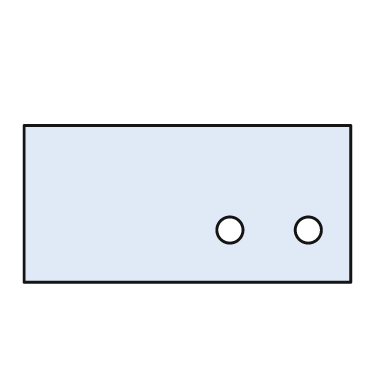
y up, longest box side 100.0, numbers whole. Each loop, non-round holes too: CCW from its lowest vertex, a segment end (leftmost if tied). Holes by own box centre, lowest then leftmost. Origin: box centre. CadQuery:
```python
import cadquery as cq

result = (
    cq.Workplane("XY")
    .moveTo(-50.0, -24.0)
    .lineTo(50.0, -24.0)
    .lineTo(50.0, 24.0)
    .lineTo(-50.0, 24.0)
    .close()
    .moveTo(13.0, -8.0)
    .circle(4.0)
    .moveTo(37.0, -8.0)
    .circle(4.0)
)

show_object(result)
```